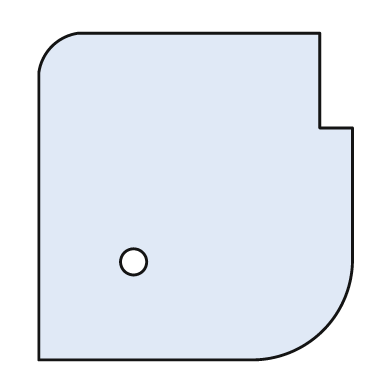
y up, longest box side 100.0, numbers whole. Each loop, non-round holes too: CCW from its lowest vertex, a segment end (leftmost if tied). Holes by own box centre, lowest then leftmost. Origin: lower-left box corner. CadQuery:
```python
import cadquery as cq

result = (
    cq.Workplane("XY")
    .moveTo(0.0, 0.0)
    .lineTo(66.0, 0.0)
    .threePointArc((87.0, 9.0), (96.0, 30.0))
    .lineTo(96.0, 71.0)
    .lineTo(86.0, 71.0)
    .lineTo(86.0, 100.0)
    .lineTo(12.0, 100.0)
    .threePointArc((4.0, 96.0), (0.0, 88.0))
    .close()
    .moveTo(29.0, 30.0)
    .circle(4.0)
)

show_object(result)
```